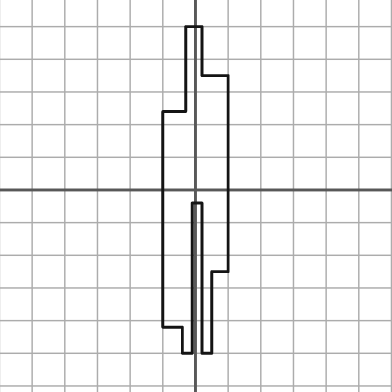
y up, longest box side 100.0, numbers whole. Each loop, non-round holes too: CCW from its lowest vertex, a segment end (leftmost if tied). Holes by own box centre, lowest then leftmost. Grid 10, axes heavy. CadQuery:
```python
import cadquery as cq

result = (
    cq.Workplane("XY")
    .moveTo(-4.0, -50.0)
    .lineTo(-1.0, -50.0)
    .lineTo(-1.0, -4.0)
    .lineTo(2.0, -4.0)
    .lineTo(2.0, -50.0)
    .lineTo(5.0, -50.0)
    .lineTo(5.0, -25.0)
    .lineTo(10.0, -25.0)
    .lineTo(10.0, 35.0)
    .lineTo(2.0, 35.0)
    .lineTo(2.0, 50.0)
    .lineTo(-3.0, 50.0)
    .lineTo(-3.0, 24.0)
    .lineTo(-10.0, 24.0)
    .lineTo(-10.0, -42.0)
    .lineTo(-4.0, -42.0)
    .close()
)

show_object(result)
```